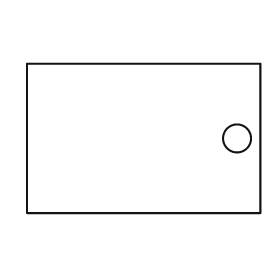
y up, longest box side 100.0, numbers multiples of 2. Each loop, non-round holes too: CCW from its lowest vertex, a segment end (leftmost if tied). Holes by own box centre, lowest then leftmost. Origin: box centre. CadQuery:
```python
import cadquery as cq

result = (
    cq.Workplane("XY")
    .moveTo(-50.0, -32.0)
    .lineTo(50.0, -32.0)
    .lineTo(50.0, 32.0)
    .lineTo(-50.0, 32.0)
    .close()
    .moveTo(40.0, 0.0)
    .circle(6.0)
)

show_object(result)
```